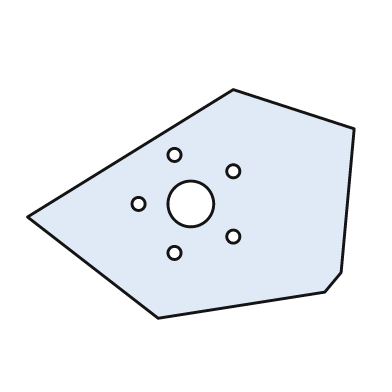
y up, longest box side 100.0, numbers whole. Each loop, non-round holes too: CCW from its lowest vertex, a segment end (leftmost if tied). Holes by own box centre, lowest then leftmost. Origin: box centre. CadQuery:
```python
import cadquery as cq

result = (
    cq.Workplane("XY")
    .moveTo(-10.0, -35.0)
    .lineTo(41.0, -27.0)
    .lineTo(46.0, -21.0)
    .lineTo(50.0, 23.0)
    .lineTo(13.0, 35.0)
    .lineTo(-50.0, -4.0)
    .close()
    .moveTo(-5.0, -15.0)
    .circle(2.0)
    .moveTo(13.0, -10.0)
    .circle(2.0)
    .moveTo(-16.0, 0.0)
    .circle(2.0)
    .moveTo(0.0, 0.0)
    .circle(7.0)
    .moveTo(13.0, 10.0)
    .circle(2.0)
    .moveTo(-5.0, 15.0)
    .circle(2.0)
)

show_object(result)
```